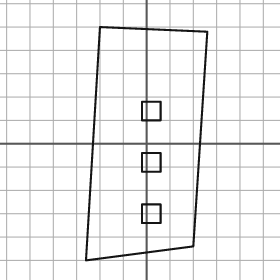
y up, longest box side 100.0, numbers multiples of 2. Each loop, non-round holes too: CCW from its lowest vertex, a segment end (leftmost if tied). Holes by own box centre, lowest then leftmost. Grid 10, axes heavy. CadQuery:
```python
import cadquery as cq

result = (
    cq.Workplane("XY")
    .moveTo(-26.0, -50.0)
    .lineTo(20.0, -44.0)
    .lineTo(26.0, 48.0)
    .lineTo(-20.0, 50.0)
    .close()
    .moveTo(-2.0, -34.0)
    .lineTo(6.0, -34.0)
    .lineTo(6.0, -26.0)
    .lineTo(-2.0, -26.0)
    .close()
    .moveTo(-2.0, -12.0)
    .lineTo(6.0, -12.0)
    .lineTo(6.0, -4.0)
    .lineTo(-2.0, -4.0)
    .close()
    .moveTo(-2.0, 10.0)
    .lineTo(6.0, 10.0)
    .lineTo(6.0, 18.0)
    .lineTo(-2.0, 18.0)
    .close()
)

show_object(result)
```